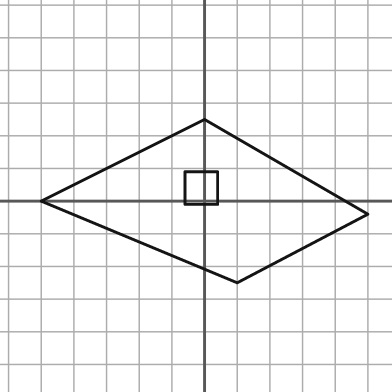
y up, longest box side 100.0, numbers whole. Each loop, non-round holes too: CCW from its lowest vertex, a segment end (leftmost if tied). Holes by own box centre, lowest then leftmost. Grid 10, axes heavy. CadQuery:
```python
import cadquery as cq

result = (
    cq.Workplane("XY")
    .moveTo(10.0, -25.0)
    .lineTo(50.0, -4.0)
    .lineTo(0.0, 25.0)
    .lineTo(-50.0, 0.0)
    .close()
    .moveTo(-6.0, -1.0)
    .lineTo(4.0, -1.0)
    .lineTo(4.0, 9.0)
    .lineTo(-6.0, 9.0)
    .close()
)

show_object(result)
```